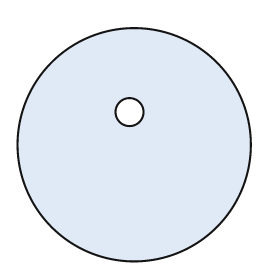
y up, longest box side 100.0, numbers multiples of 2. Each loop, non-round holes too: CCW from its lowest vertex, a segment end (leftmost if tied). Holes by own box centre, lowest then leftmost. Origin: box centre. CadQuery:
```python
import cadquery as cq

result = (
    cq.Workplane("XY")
    .moveTo(0.0, 0.0)
    .circle(50.0)
    .moveTo(-2.0, 14.0)
    .circle(6.0)
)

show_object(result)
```